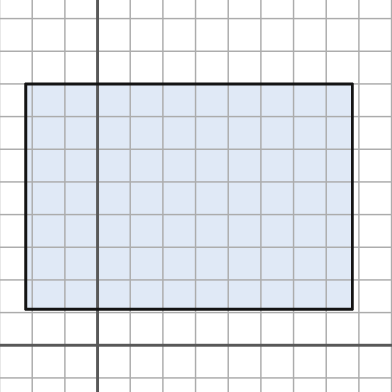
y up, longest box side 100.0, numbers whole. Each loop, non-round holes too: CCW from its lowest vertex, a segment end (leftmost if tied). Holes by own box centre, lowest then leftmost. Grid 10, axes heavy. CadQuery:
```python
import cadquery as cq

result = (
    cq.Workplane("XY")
    .moveTo(-22.0, 11.0)
    .lineTo(78.0, 11.0)
    .lineTo(78.0, 80.0)
    .lineTo(-22.0, 80.0)
    .close()
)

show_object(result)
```